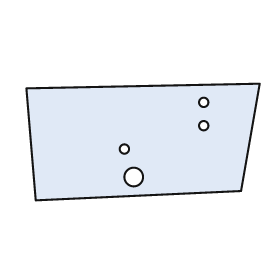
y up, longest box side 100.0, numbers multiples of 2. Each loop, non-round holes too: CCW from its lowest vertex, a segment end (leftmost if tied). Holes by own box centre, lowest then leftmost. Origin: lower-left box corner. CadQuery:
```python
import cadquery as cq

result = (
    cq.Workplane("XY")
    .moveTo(4.0, 0.0)
    .lineTo(92.0, 4.0)
    .lineTo(100.0, 50.0)
    .lineTo(0.0, 48.0)
    .close()
    .moveTo(46.0, 10.0)
    .circle(4.0)
    .moveTo(42.0, 22.0)
    .circle(2.0)
    .moveTo(76.0, 32.0)
    .circle(2.0)
    .moveTo(76.0, 42.0)
    .circle(2.0)
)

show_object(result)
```